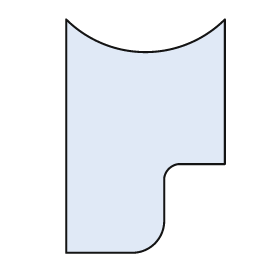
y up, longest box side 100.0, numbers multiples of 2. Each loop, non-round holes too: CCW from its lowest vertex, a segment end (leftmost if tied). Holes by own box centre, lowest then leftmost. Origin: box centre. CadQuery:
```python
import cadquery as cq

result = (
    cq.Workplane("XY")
    .moveTo(-34.0, -50.0)
    .lineTo(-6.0, -50.0)
    .threePointArc((4.0, -46.0), (8.0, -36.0))
    .lineTo(8.0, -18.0)
    .threePointArc((10.0, -14.0), (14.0, -12.0))
    .lineTo(34.0, -12.0)
    .lineTo(34.0, 50.0)
    .threePointArc((0.0, 36.0), (-34.0, 50.0))
    .close()
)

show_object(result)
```